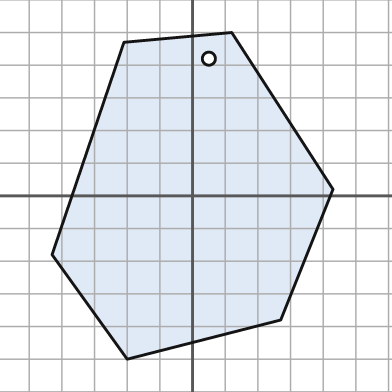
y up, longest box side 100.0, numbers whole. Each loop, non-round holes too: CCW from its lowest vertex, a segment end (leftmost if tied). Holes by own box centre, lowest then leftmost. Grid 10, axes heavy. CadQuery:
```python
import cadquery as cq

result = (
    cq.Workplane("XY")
    .moveTo(-20.0, -50.0)
    .lineTo(27.0, -38.0)
    .lineTo(43.0, 2.0)
    .lineTo(12.0, 50.0)
    .lineTo(-21.0, 47.0)
    .lineTo(-43.0, -18.0)
    .close()
    .moveTo(5.0, 42.0)
    .circle(2.0)
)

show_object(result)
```